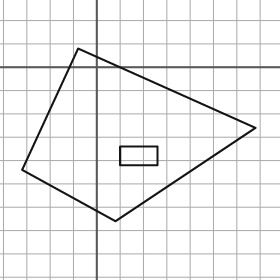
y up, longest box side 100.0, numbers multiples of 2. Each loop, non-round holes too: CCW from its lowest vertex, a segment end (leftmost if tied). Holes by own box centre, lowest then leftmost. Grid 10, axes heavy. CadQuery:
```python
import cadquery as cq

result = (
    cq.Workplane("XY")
    .moveTo(8.0, -66.0)
    .lineTo(68.0, -26.0)
    .lineTo(-8.0, 8.0)
    .lineTo(-32.0, -44.0)
    .close()
    .moveTo(10.0, -42.0)
    .lineTo(26.0, -42.0)
    .lineTo(26.0, -34.0)
    .lineTo(10.0, -34.0)
    .close()
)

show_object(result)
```